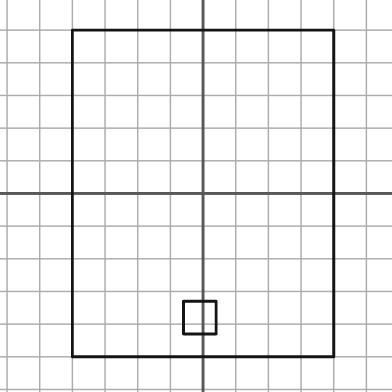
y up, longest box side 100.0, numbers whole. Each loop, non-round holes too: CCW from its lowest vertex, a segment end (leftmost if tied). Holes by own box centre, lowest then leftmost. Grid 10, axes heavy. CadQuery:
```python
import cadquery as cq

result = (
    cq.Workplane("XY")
    .moveTo(-40.0, -50.0)
    .lineTo(40.0, -50.0)
    .lineTo(40.0, 50.0)
    .lineTo(-40.0, 50.0)
    .close()
    .moveTo(-6.0, -43.0)
    .lineTo(4.0, -43.0)
    .lineTo(4.0, -33.0)
    .lineTo(-6.0, -33.0)
    .close()
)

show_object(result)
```